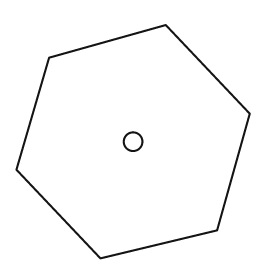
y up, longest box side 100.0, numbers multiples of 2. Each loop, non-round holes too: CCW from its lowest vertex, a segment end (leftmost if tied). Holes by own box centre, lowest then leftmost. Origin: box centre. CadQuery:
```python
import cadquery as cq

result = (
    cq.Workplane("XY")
    .moveTo(-14.0, -50.0)
    .lineTo(36.0, -38.0)
    .lineTo(50.0, 12.0)
    .lineTo(14.0, 50.0)
    .lineTo(-36.0, 36.0)
    .lineTo(-50.0, -12.0)
    .close()
    .moveTo(0.0, 0.0)
    .circle(4.0)
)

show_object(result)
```